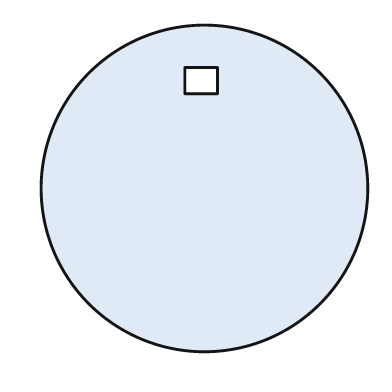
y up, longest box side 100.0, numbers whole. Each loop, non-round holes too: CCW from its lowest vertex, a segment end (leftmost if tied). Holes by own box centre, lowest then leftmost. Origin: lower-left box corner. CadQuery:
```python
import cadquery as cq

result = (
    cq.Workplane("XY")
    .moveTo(50.0, 50.0)
    .circle(50.0)
    .moveTo(44.0, 79.0)
    .lineTo(54.0, 79.0)
    .lineTo(54.0, 87.0)
    .lineTo(44.0, 87.0)
    .close()
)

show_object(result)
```